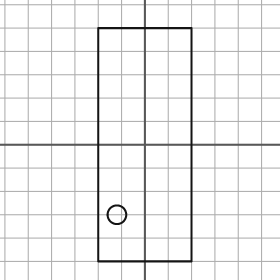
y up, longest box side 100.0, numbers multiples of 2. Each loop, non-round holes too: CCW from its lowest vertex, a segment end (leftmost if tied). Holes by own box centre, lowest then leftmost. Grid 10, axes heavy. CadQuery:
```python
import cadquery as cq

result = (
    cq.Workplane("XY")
    .moveTo(-20.0, -50.0)
    .lineTo(20.0, -50.0)
    .lineTo(20.0, 50.0)
    .lineTo(-20.0, 50.0)
    .close()
    .moveTo(-12.0, -30.0)
    .circle(4.0)
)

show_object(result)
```